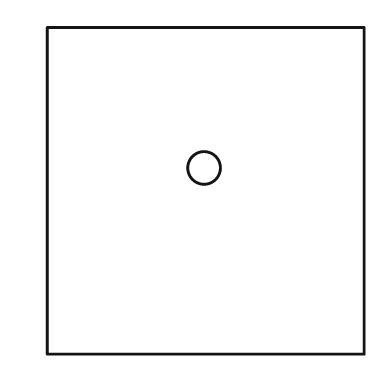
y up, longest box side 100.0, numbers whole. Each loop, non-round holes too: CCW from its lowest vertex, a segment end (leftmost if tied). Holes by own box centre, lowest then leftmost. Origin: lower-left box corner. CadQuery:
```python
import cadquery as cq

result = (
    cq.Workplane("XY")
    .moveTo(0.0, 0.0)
    .lineTo(97.0, 0.0)
    .lineTo(97.0, 100.0)
    .lineTo(0.0, 100.0)
    .close()
    .moveTo(48.0, 57.0)
    .circle(5.0)
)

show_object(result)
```